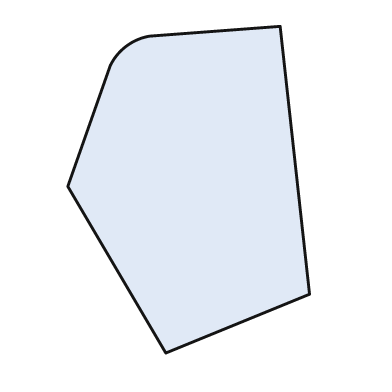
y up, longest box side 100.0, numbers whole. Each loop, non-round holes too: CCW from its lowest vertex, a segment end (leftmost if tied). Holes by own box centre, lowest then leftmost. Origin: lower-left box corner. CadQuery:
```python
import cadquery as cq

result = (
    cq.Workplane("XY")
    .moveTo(30.0, 0.0)
    .lineTo(74.0, 18.0)
    .lineTo(65.0, 100.0)
    .lineTo(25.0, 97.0)
    .threePointArc((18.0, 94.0), (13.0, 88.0))
    .lineTo(0.0, 51.0)
    .close()
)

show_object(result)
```